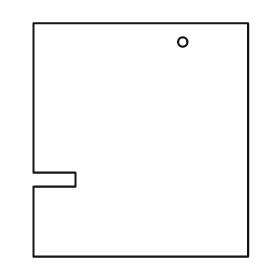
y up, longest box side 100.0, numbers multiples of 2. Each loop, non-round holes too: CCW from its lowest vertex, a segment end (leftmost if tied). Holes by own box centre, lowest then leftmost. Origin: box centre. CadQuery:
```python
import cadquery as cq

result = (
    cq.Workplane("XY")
    .moveTo(-46.0, -50.0)
    .lineTo(46.0, -50.0)
    .lineTo(46.0, 50.0)
    .lineTo(-46.0, 50.0)
    .lineTo(-46.0, -14.0)
    .lineTo(-28.0, -14.0)
    .lineTo(-28.0, -20.0)
    .lineTo(-46.0, -20.0)
    .close()
    .moveTo(18.0, 42.0)
    .circle(2.0)
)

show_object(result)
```